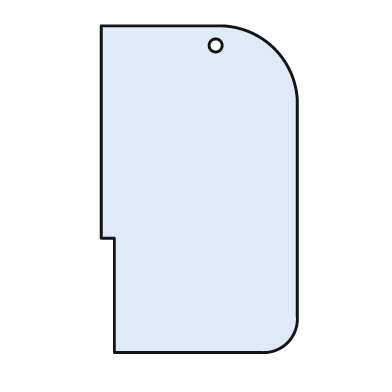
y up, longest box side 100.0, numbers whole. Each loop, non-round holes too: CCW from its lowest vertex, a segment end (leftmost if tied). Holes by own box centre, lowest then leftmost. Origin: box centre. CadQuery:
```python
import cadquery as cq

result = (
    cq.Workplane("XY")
    .moveTo(-26.0, -50.0)
    .lineTo(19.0, -50.0)
    .threePointArc((27.0, -47.0), (30.0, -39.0))
    .lineTo(30.0, 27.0)
    .threePointArc((23.0, 43.0), (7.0, 50.0))
    .lineTo(-30.0, 50.0)
    .lineTo(-30.0, -15.0)
    .lineTo(-26.0, -15.0)
    .close()
    .moveTo(5.0, 44.0)
    .circle(2.0)
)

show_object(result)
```